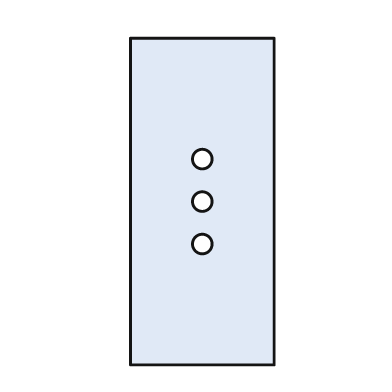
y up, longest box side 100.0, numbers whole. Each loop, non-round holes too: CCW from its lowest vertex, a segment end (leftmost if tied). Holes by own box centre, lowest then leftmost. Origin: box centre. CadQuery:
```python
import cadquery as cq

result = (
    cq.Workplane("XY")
    .moveTo(-22.0, -50.0)
    .lineTo(22.0, -50.0)
    .lineTo(22.0, 50.0)
    .lineTo(-22.0, 50.0)
    .close()
    .moveTo(0.0, -13.0)
    .circle(3.0)
    .moveTo(0.0, 0.0)
    .circle(3.0)
    .moveTo(0.0, 13.0)
    .circle(3.0)
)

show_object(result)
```